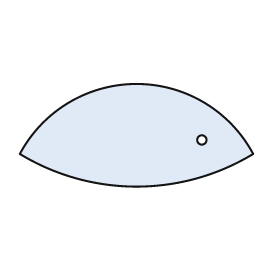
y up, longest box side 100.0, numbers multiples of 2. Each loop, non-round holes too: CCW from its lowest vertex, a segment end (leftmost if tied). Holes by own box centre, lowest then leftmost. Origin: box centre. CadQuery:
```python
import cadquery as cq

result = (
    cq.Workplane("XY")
    .moveTo(-50.0, -8.0)
    .threePointArc((0.0, -22.0), (50.0, -8.0))
    .threePointArc((0.0, 22.0), (-50.0, -8.0))
    .close()
    .moveTo(28.0, -2.0)
    .circle(2.0)
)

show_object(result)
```